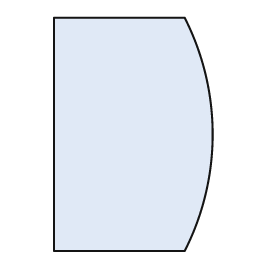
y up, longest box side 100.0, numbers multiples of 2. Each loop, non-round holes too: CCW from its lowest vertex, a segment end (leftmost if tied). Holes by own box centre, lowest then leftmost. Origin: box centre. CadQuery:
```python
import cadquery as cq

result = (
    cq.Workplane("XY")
    .moveTo(-34.0, -50.0)
    .lineTo(22.0, -50.0)
    .threePointArc((34.0, 0.0), (22.0, 50.0))
    .lineTo(-34.0, 50.0)
    .close()
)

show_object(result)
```